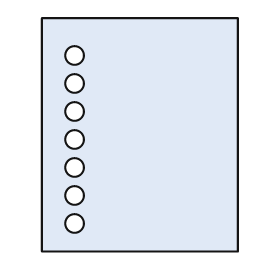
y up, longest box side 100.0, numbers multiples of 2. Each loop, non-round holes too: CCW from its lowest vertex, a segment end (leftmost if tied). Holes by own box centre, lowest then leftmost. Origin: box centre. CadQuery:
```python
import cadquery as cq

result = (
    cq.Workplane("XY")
    .moveTo(-42.0, -50.0)
    .lineTo(42.0, -50.0)
    .lineTo(42.0, 50.0)
    .lineTo(-42.0, 50.0)
    .close()
    .moveTo(-28.0, -38.0)
    .circle(4.0)
    .moveTo(-28.0, -26.0)
    .circle(4.0)
    .moveTo(-28.0, -14.0)
    .circle(4.0)
    .moveTo(-28.0, -2.0)
    .circle(4.0)
    .moveTo(-28.0, 10.0)
    .circle(4.0)
    .moveTo(-28.0, 22.0)
    .circle(4.0)
    .moveTo(-28.0, 34.0)
    .circle(4.0)
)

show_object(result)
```